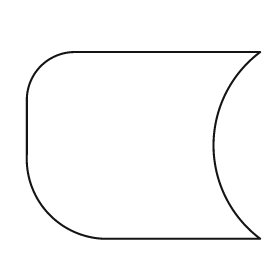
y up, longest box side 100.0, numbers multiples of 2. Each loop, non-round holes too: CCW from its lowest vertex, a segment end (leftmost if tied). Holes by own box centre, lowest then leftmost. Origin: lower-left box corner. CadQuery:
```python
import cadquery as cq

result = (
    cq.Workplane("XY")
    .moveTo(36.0, 0.0)
    .lineTo(100.0, 0.0)
    .threePointArc((80.0, 40.0), (100.0, 80.0))
    .lineTo(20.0, 80.0)
    .threePointArc((6.0, 74.0), (0.0, 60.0))
    .lineTo(0.0, 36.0)
    .threePointArc((10.0, 10.0), (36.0, 0.0))
    .close()
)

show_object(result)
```